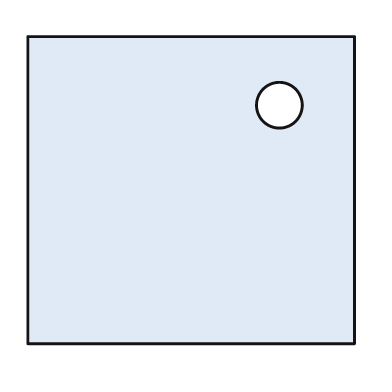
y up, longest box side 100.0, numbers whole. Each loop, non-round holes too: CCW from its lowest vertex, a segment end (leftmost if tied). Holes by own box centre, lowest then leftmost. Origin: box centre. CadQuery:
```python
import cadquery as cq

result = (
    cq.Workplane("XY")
    .moveTo(-50.0, -47.0)
    .lineTo(50.0, -47.0)
    .lineTo(50.0, 47.0)
    .lineTo(-50.0, 47.0)
    .close()
    .moveTo(27.0, 26.0)
    .circle(7.0)
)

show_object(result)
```